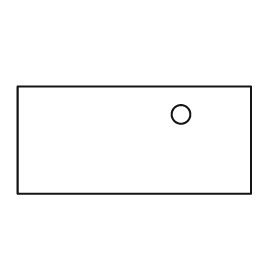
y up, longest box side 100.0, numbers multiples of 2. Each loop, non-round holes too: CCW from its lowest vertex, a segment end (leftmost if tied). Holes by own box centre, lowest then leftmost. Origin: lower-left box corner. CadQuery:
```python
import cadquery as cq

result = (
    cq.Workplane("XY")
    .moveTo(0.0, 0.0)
    .lineTo(100.0, 0.0)
    .lineTo(100.0, 46.0)
    .lineTo(0.0, 46.0)
    .close()
    .moveTo(70.0, 34.0)
    .circle(4.0)
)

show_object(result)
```